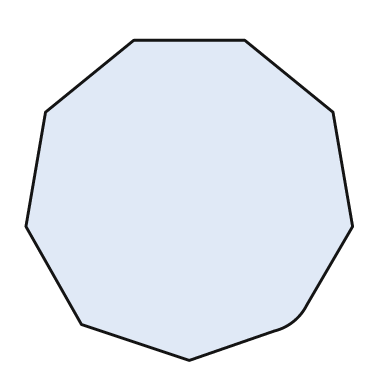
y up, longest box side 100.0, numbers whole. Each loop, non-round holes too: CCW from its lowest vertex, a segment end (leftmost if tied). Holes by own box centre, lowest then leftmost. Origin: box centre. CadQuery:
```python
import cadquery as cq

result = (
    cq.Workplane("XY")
    .moveTo(0.0, -49.0)
    .lineTo(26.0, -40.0)
    .threePointArc((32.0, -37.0), (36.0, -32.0))
    .lineTo(50.0, -8.0)
    .lineTo(44.0, 27.0)
    .lineTo(17.0, 49.0)
    .lineTo(-17.0, 49.0)
    .lineTo(-44.0, 27.0)
    .lineTo(-50.0, -8.0)
    .lineTo(-33.0, -38.0)
    .close()
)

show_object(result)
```